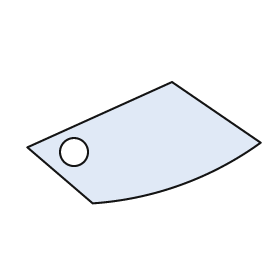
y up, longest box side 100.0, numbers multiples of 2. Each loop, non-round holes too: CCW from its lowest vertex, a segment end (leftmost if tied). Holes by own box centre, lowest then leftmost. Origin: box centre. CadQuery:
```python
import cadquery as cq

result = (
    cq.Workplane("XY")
    .moveTo(-22.0, -26.0)
    .threePointArc((16.0, -18.0), (50.0, 0.0))
    .lineTo(12.0, 26.0)
    .lineTo(-50.0, -2.0)
    .close()
    .moveTo(-30.0, -4.0)
    .circle(6.0)
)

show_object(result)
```